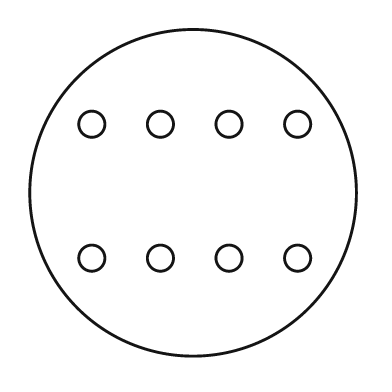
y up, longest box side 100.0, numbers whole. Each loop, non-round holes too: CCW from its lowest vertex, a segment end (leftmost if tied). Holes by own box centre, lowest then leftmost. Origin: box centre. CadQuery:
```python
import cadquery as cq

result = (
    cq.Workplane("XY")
    .moveTo(0.0, 0.0)
    .circle(50.0)
    .moveTo(-31.0, -20.0)
    .circle(4.0)
    .moveTo(-10.0, -20.0)
    .circle(4.0)
    .moveTo(11.0, -20.0)
    .circle(4.0)
    .moveTo(32.0, -20.0)
    .circle(4.0)
    .moveTo(-31.0, 21.0)
    .circle(4.0)
    .moveTo(-10.0, 21.0)
    .circle(4.0)
    .moveTo(11.0, 21.0)
    .circle(4.0)
    .moveTo(32.0, 21.0)
    .circle(4.0)
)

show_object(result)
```